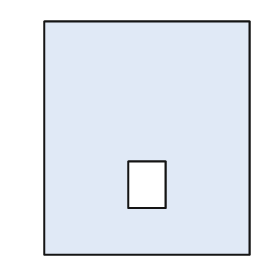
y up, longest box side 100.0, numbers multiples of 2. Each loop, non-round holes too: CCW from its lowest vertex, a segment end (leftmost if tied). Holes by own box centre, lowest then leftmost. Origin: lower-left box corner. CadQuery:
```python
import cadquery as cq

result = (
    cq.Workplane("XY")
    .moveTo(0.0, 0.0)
    .lineTo(88.0, 0.0)
    .lineTo(88.0, 100.0)
    .lineTo(0.0, 100.0)
    .close()
    .moveTo(36.0, 20.0)
    .lineTo(52.0, 20.0)
    .lineTo(52.0, 40.0)
    .lineTo(36.0, 40.0)
    .close()
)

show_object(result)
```